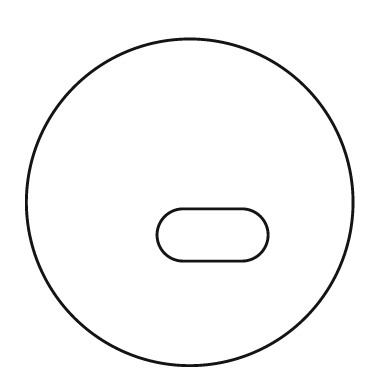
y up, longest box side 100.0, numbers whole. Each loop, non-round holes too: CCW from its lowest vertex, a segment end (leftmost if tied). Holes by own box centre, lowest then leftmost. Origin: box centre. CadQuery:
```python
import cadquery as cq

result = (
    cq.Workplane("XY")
    .moveTo(0.0, 0.0)
    .circle(50.0)
    .moveTo(-2.0, -18.0)
    .lineTo(16.0, -18.0)
    .threePointArc((24.0, -10.0), (16.0, -2.0))
    .lineTo(-2.0, -2.0)
    .threePointArc((-10.0, -10.0), (-2.0, -18.0))
    .close()
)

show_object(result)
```